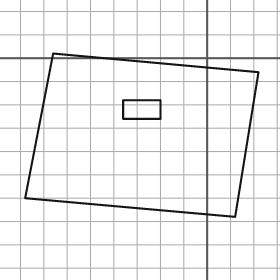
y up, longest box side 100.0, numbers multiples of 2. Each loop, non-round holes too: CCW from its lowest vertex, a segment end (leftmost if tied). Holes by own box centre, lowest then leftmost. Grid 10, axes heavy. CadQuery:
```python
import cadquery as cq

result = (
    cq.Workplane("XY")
    .moveTo(12.0, -68.0)
    .lineTo(22.0, -6.0)
    .lineTo(-66.0, 2.0)
    .lineTo(-78.0, -60.0)
    .close()
    .moveTo(-36.0, -26.0)
    .lineTo(-20.0, -26.0)
    .lineTo(-20.0, -18.0)
    .lineTo(-36.0, -18.0)
    .close()
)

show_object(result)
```